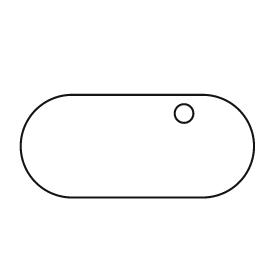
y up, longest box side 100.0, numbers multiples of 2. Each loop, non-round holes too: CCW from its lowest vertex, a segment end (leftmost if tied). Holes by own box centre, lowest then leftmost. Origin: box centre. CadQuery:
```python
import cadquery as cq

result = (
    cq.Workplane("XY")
    .moveTo(-28.0, -22.0)
    .lineTo(28.0, -22.0)
    .threePointArc((50.0, 0.0), (28.0, 22.0))
    .lineTo(-28.0, 22.0)
    .threePointArc((-50.0, 0.0), (-28.0, -22.0))
    .close()
    .moveTo(20.0, 14.0)
    .circle(4.0)
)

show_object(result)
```